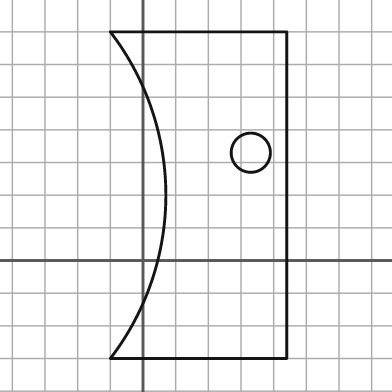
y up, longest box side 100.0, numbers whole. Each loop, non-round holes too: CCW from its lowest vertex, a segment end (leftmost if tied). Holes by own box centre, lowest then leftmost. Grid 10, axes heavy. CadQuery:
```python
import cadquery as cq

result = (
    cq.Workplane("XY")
    .moveTo(-10.0, -30.0)
    .lineTo(44.0, -30.0)
    .lineTo(44.0, 70.0)
    .lineTo(-10.0, 70.0)
    .threePointArc((7.0, 20.0), (-10.0, -30.0))
    .close()
    .moveTo(33.0, 33.0)
    .circle(6.0)
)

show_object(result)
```